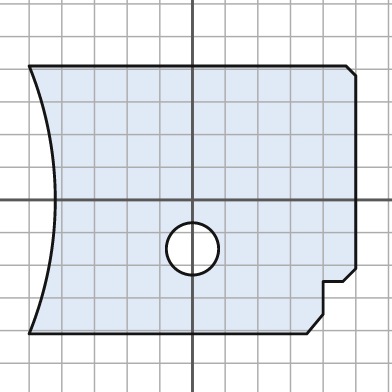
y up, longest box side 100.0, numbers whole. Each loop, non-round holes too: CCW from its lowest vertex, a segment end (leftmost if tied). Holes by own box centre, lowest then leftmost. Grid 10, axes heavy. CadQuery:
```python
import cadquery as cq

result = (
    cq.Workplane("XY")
    .moveTo(-50.0, -41.0)
    .lineTo(35.0, -41.0)
    .lineTo(40.0, -35.0)
    .lineTo(40.0, -25.0)
    .lineTo(46.0, -25.0)
    .lineTo(50.0, -21.0)
    .lineTo(50.0, 38.0)
    .lineTo(47.0, 41.0)
    .lineTo(-50.0, 41.0)
    .threePointArc((-42.0, 0.0), (-50.0, -41.0))
    .close()
    .moveTo(0.0, -15.0)
    .circle(8.0)
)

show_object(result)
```